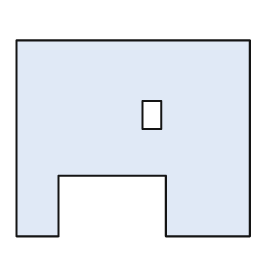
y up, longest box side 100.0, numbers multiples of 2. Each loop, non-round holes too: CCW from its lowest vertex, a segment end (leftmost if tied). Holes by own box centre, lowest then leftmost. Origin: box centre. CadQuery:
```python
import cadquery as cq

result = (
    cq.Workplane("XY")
    .moveTo(-50.0, -42.0)
    .lineTo(-32.0, -42.0)
    .lineTo(-32.0, -16.0)
    .lineTo(14.0, -16.0)
    .lineTo(14.0, -42.0)
    .lineTo(50.0, -42.0)
    .lineTo(50.0, 42.0)
    .lineTo(-50.0, 42.0)
    .close()
    .moveTo(4.0, 4.0)
    .lineTo(12.0, 4.0)
    .lineTo(12.0, 16.0)
    .lineTo(4.0, 16.0)
    .close()
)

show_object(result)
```